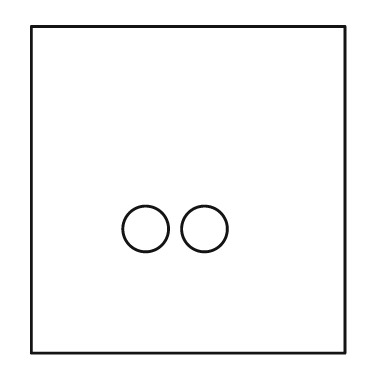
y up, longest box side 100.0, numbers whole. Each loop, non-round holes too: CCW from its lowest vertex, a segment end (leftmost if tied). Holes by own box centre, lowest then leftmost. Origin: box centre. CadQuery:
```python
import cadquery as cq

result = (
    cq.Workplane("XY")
    .moveTo(-48.0, -50.0)
    .lineTo(48.0, -50.0)
    .lineTo(48.0, 50.0)
    .lineTo(-48.0, 50.0)
    .close()
    .moveTo(-13.0, -12.0)
    .circle(7.0)
    .moveTo(5.0, -12.0)
    .circle(7.0)
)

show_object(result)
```